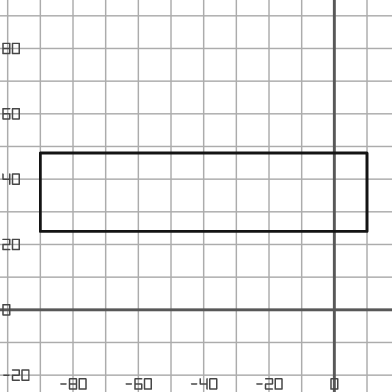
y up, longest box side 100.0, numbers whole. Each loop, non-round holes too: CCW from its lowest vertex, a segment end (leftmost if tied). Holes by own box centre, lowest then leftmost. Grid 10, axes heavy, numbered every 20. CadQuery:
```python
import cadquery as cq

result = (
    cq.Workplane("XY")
    .moveTo(-90.0, 24.0)
    .lineTo(10.0, 24.0)
    .lineTo(10.0, 48.0)
    .lineTo(-90.0, 48.0)
    .close()
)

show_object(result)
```